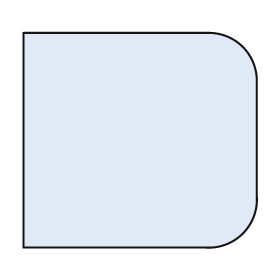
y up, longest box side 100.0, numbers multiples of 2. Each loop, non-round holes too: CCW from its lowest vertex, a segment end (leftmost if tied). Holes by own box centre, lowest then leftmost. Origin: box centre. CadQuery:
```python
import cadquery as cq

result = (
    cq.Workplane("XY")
    .moveTo(-50.0, -46.0)
    .lineTo(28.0, -46.0)
    .threePointArc((44.0, -40.0), (50.0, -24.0))
    .lineTo(50.0, 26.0)
    .threePointArc((44.0, 40.0), (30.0, 46.0))
    .lineTo(-50.0, 46.0)
    .close()
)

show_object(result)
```